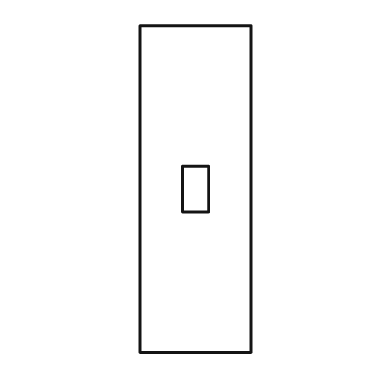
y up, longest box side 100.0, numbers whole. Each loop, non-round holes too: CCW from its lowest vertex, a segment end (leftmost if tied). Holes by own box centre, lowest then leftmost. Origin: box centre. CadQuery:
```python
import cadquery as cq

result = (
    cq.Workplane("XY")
    .moveTo(-17.0, -50.0)
    .lineTo(17.0, -50.0)
    .lineTo(17.0, 50.0)
    .lineTo(-17.0, 50.0)
    .close()
    .moveTo(-4.0, -7.0)
    .lineTo(4.0, -7.0)
    .lineTo(4.0, 7.0)
    .lineTo(-4.0, 7.0)
    .close()
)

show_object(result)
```